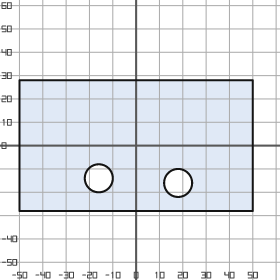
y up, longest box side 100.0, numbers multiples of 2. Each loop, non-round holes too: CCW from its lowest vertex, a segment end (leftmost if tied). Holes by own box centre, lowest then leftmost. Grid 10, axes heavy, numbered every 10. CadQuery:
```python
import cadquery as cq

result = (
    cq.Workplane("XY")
    .moveTo(-50.0, -28.0)
    .lineTo(50.0, -28.0)
    .lineTo(50.0, 28.0)
    .lineTo(-50.0, 28.0)
    .close()
    .moveTo(18.0, -16.0)
    .circle(6.0)
    .moveTo(-16.0, -14.0)
    .circle(6.0)
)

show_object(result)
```